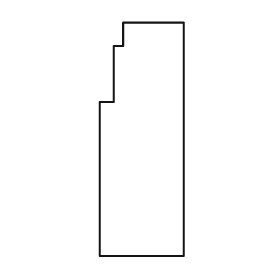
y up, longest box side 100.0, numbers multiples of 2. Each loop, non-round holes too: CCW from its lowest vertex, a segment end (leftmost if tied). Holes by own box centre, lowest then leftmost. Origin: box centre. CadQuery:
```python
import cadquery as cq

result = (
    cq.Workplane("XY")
    .moveTo(-18.0, -50.0)
    .lineTo(18.0, -50.0)
    .lineTo(18.0, 50.0)
    .lineTo(-8.0, 50.0)
    .lineTo(-8.0, 40.0)
    .lineTo(-12.0, 40.0)
    .lineTo(-12.0, 16.0)
    .lineTo(-18.0, 16.0)
    .close()
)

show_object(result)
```